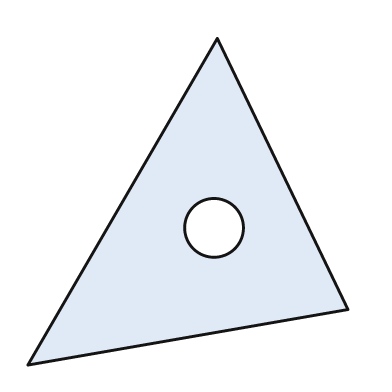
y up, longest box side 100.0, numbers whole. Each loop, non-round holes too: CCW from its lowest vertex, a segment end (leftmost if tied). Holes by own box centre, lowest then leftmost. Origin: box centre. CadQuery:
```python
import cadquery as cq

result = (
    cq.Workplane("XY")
    .moveTo(-49.0, -50.0)
    .lineTo(49.0, -33.0)
    .lineTo(9.0, 50.0)
    .close()
    .moveTo(8.0, -8.0)
    .circle(9.0)
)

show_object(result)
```